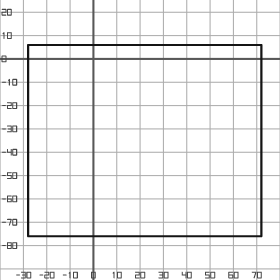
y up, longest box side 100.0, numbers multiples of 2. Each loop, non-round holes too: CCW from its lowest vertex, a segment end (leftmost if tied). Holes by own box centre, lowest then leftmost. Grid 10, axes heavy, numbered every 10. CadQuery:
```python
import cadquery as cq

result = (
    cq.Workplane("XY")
    .moveTo(-28.0, -76.0)
    .lineTo(72.0, -76.0)
    .lineTo(72.0, 6.0)
    .lineTo(-28.0, 6.0)
    .close()
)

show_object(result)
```